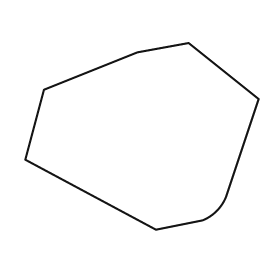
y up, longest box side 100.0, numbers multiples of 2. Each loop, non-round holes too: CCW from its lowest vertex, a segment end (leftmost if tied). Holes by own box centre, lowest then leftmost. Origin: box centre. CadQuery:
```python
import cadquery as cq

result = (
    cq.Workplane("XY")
    .moveTo(6.0, -40.0)
    .lineTo(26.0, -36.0)
    .threePointArc((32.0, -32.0), (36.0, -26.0))
    .lineTo(50.0, 16.0)
    .lineTo(20.0, 40.0)
    .lineTo(-2.0, 36.0)
    .lineTo(-42.0, 20.0)
    .lineTo(-50.0, -10.0)
    .close()
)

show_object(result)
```